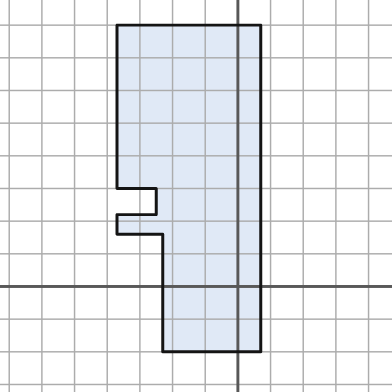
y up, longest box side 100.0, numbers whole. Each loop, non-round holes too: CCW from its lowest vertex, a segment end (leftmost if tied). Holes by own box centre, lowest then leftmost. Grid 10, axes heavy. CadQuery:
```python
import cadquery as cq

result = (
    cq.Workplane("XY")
    .moveTo(-23.0, -20.0)
    .lineTo(7.0, -20.0)
    .lineTo(7.0, 80.0)
    .lineTo(-37.0, 80.0)
    .lineTo(-37.0, 30.0)
    .lineTo(-25.0, 30.0)
    .lineTo(-25.0, 22.0)
    .lineTo(-37.0, 22.0)
    .lineTo(-37.0, 16.0)
    .lineTo(-23.0, 16.0)
    .close()
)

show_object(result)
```